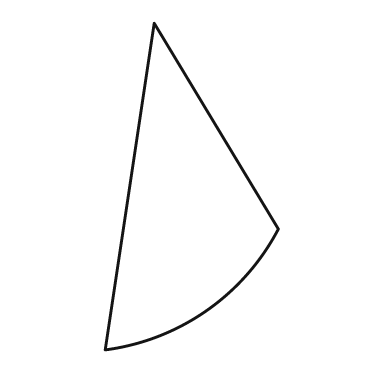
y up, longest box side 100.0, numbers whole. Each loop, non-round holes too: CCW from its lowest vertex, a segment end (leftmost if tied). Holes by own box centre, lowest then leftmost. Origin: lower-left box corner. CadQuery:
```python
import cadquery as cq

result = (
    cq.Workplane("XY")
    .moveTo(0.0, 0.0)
    .threePointArc((31.0, 12.0), (53.0, 37.0))
    .lineTo(15.0, 100.0)
    .close()
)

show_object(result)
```